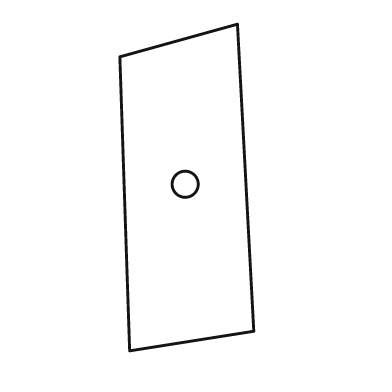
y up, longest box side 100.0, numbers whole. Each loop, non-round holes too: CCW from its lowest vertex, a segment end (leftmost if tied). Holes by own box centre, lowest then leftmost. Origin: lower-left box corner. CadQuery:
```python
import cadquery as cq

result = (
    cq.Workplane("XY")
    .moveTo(3.0, 0.0)
    .lineTo(41.0, 6.0)
    .lineTo(36.0, 100.0)
    .lineTo(0.0, 90.0)
    .close()
    .moveTo(20.0, 51.0)
    .circle(4.0)
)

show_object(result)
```